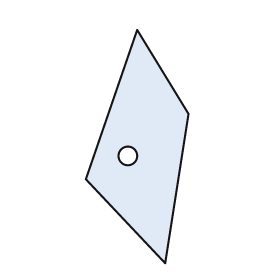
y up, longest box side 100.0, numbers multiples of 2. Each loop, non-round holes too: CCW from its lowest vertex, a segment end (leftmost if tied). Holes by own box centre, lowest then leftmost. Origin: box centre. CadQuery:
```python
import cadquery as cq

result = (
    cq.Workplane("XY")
    .moveTo(12.0, -50.0)
    .lineTo(22.0, 14.0)
    .lineTo(0.0, 50.0)
    .lineTo(-22.0, -14.0)
    .close()
    .moveTo(-4.0, -4.0)
    .circle(4.0)
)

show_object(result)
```